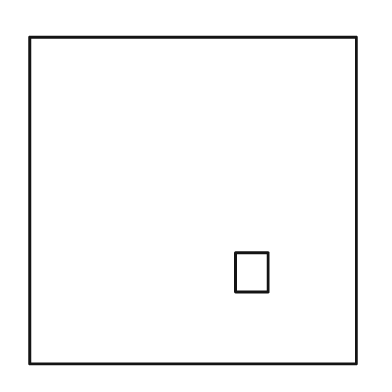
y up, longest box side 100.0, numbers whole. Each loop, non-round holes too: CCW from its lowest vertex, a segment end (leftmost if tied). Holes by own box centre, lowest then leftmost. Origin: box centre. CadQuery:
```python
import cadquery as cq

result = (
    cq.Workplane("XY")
    .moveTo(-50.0, -50.0)
    .lineTo(50.0, -50.0)
    .lineTo(50.0, 50.0)
    .lineTo(-50.0, 50.0)
    .close()
    .moveTo(13.0, -28.0)
    .lineTo(23.0, -28.0)
    .lineTo(23.0, -16.0)
    .lineTo(13.0, -16.0)
    .close()
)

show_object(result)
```